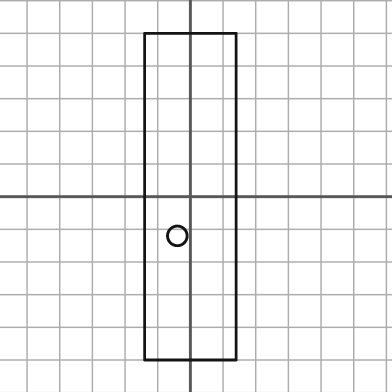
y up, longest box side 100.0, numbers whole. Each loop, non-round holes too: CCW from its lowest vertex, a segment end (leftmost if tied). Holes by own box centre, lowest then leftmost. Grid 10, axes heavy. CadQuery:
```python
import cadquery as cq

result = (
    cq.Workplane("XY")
    .moveTo(-14.0, -50.0)
    .lineTo(14.0, -50.0)
    .lineTo(14.0, 50.0)
    .lineTo(-14.0, 50.0)
    .close()
    .moveTo(-4.0, -12.0)
    .circle(3.0)
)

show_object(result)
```